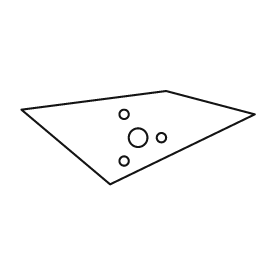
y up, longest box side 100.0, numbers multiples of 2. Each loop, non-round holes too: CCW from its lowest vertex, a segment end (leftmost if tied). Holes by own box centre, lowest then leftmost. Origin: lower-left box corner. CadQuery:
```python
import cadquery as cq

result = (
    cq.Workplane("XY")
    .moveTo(38.0, 0.0)
    .lineTo(100.0, 30.0)
    .lineTo(62.0, 40.0)
    .lineTo(0.0, 32.0)
    .close()
    .moveTo(44.0, 10.0)
    .circle(2.0)
    .moveTo(50.0, 20.0)
    .circle(4.0)
    .moveTo(60.0, 20.0)
    .circle(2.0)
    .moveTo(44.0, 30.0)
    .circle(2.0)
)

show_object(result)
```